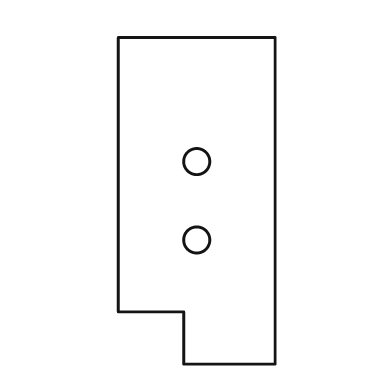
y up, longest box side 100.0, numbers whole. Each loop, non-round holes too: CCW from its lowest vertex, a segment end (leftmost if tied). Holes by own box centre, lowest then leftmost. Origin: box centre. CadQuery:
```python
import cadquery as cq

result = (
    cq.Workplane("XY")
    .moveTo(-4.0, -50.0)
    .lineTo(24.0, -50.0)
    .lineTo(24.0, 50.0)
    .lineTo(-24.0, 50.0)
    .lineTo(-24.0, -34.0)
    .lineTo(-4.0, -34.0)
    .close()
    .moveTo(0.0, -12.0)
    .circle(4.0)
    .moveTo(0.0, 12.0)
    .circle(4.0)
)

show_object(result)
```